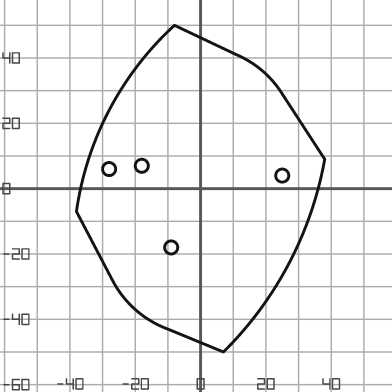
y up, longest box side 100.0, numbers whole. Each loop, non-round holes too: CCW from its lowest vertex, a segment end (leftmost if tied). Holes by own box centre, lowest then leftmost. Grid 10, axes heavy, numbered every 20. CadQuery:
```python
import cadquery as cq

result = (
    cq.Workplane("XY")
    .moveTo(7.0, -50.0)
    .threePointArc((27.0, -23.0), (38.0, 9.0))
    .lineTo(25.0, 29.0)
    .threePointArc((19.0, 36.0), (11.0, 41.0))
    .lineTo(-8.0, 50.0)
    .threePointArc((-28.0, 24.0), (-38.0, -7.0))
    .lineTo(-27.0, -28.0)
    .threePointArc((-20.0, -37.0), (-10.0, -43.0))
    .close()
    .moveTo(-9.0, -18.0)
    .circle(2.0)
    .moveTo(25.0, 4.0)
    .circle(2.0)
    .moveTo(-28.0, 6.0)
    .circle(2.0)
    .moveTo(-18.0, 7.0)
    .circle(2.0)
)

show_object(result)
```